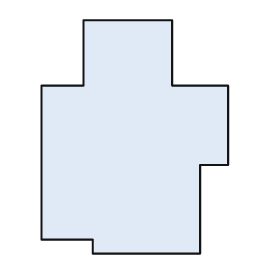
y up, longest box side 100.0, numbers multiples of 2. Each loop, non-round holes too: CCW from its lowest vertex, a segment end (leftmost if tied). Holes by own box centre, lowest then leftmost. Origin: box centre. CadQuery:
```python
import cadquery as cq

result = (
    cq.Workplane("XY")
    .moveTo(-18.0, -50.0)
    .lineTo(28.0, -50.0)
    .lineTo(28.0, -12.0)
    .lineTo(40.0, -12.0)
    .lineTo(40.0, 22.0)
    .lineTo(16.0, 22.0)
    .lineTo(16.0, 50.0)
    .lineTo(-22.0, 50.0)
    .lineTo(-22.0, 22.0)
    .lineTo(-40.0, 22.0)
    .lineTo(-40.0, -44.0)
    .lineTo(-18.0, -44.0)
    .close()
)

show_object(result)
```